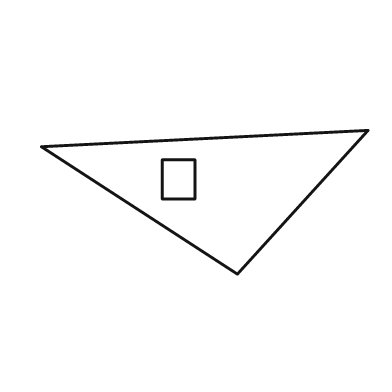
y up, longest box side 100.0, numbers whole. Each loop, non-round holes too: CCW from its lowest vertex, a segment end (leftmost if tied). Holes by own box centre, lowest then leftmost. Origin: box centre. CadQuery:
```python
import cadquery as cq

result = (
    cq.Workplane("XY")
    .moveTo(10.0, -22.0)
    .lineTo(50.0, 22.0)
    .lineTo(-50.0, 17.0)
    .close()
    .moveTo(-13.0, 1.0)
    .lineTo(-3.0, 1.0)
    .lineTo(-3.0, 13.0)
    .lineTo(-13.0, 13.0)
    .close()
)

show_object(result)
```